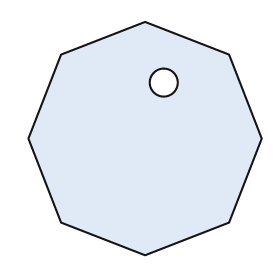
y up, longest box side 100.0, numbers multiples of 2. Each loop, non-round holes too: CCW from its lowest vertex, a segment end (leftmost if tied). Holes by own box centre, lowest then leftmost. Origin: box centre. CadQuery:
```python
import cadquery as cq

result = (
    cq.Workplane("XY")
    .moveTo(0.0, -50.0)
    .lineTo(36.0, -36.0)
    .lineTo(50.0, 0.0)
    .lineTo(36.0, 36.0)
    .lineTo(0.0, 50.0)
    .lineTo(-36.0, 36.0)
    .lineTo(-50.0, 0.0)
    .lineTo(-36.0, -36.0)
    .close()
    .moveTo(8.0, 24.0)
    .circle(6.0)
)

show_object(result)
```